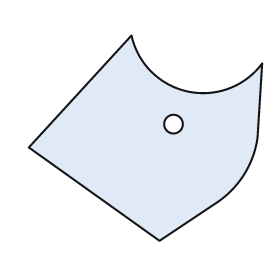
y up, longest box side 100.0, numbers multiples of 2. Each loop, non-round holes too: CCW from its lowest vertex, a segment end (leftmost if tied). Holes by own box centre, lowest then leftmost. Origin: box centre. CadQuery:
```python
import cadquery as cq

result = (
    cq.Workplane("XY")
    .moveTo(6.0, -44.0)
    .lineTo(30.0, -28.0)
    .threePointArc((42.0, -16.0), (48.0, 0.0))
    .lineTo(50.0, 32.0)
    .threePointArc((18.0, 20.0), (-6.0, 44.0))
    .lineTo(-50.0, -4.0)
    .close()
    .moveTo(12.0, 6.0)
    .circle(4.0)
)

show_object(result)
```